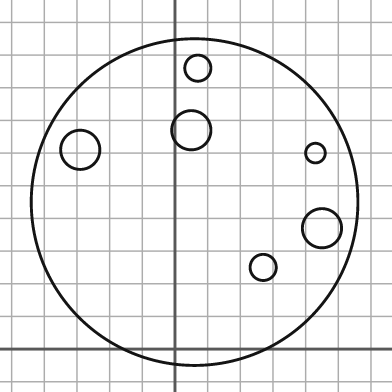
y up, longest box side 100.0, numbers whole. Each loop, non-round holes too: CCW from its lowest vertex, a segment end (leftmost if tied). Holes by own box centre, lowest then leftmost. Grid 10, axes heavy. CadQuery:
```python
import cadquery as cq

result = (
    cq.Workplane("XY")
    .moveTo(6.0, 45.0)
    .circle(50.0)
    .moveTo(27.0, 25.0)
    .circle(4.0)
    .moveTo(45.0, 37.0)
    .circle(6.0)
    .moveTo(43.0, 60.0)
    .circle(3.0)
    .moveTo(-29.0, 61.0)
    .circle(6.0)
    .moveTo(5.0, 67.0)
    .circle(6.0)
    .moveTo(7.0, 86.0)
    .circle(4.0)
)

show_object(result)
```